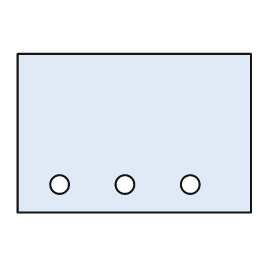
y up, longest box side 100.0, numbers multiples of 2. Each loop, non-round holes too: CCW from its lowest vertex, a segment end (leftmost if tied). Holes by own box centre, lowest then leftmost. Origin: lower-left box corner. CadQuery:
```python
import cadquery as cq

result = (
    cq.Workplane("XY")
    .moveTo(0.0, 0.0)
    .lineTo(100.0, 0.0)
    .lineTo(100.0, 68.0)
    .lineTo(0.0, 68.0)
    .close()
    .moveTo(18.0, 12.0)
    .circle(4.0)
    .moveTo(46.0, 12.0)
    .circle(4.0)
    .moveTo(74.0, 12.0)
    .circle(4.0)
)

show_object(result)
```